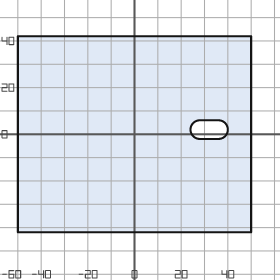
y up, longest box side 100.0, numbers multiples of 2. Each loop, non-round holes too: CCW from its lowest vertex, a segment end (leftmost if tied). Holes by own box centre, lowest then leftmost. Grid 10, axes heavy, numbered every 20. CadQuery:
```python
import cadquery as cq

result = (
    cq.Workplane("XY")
    .moveTo(-50.0, -42.0)
    .lineTo(50.0, -42.0)
    .lineTo(50.0, 42.0)
    .lineTo(-50.0, 42.0)
    .close()
    .moveTo(28.0, -2.0)
    .lineTo(36.0, -2.0)
    .threePointArc((40.0, 2.0), (36.0, 6.0))
    .lineTo(28.0, 6.0)
    .threePointArc((24.0, 2.0), (28.0, -2.0))
    .close()
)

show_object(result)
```